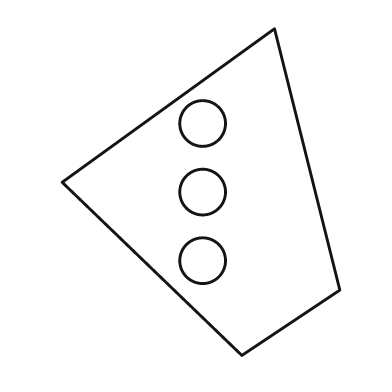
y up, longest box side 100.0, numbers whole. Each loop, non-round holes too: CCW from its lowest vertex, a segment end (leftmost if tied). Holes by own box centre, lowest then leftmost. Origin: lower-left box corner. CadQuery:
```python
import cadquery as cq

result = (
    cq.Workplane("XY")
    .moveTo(55.0, 0.0)
    .lineTo(85.0, 20.0)
    .lineTo(65.0, 100.0)
    .lineTo(0.0, 53.0)
    .close()
    .moveTo(43.0, 29.0)
    .circle(7.0)
    .moveTo(43.0, 50.0)
    .circle(7.0)
    .moveTo(43.0, 71.0)
    .circle(7.0)
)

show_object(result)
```